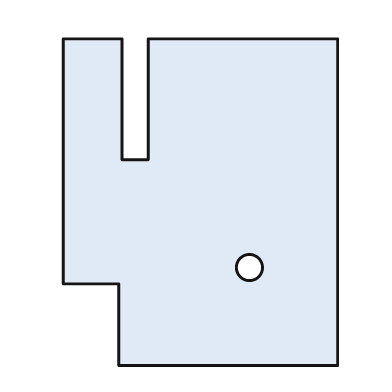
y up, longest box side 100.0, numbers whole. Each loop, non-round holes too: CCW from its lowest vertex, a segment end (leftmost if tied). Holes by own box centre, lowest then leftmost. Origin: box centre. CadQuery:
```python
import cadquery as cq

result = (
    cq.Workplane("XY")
    .moveTo(-25.0, -50.0)
    .lineTo(42.0, -50.0)
    .lineTo(42.0, 50.0)
    .lineTo(-16.0, 50.0)
    .lineTo(-16.0, 13.0)
    .lineTo(-24.0, 13.0)
    .lineTo(-24.0, 50.0)
    .lineTo(-42.0, 50.0)
    .lineTo(-42.0, -25.0)
    .lineTo(-25.0, -25.0)
    .close()
    .moveTo(15.0, -20.0)
    .circle(4.0)
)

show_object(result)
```